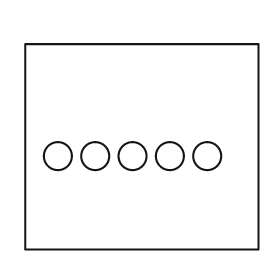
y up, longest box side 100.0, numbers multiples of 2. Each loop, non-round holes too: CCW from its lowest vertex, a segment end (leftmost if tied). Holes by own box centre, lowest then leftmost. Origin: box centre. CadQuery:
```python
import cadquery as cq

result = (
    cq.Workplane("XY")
    .moveTo(-50.0, -44.0)
    .lineTo(50.0, -44.0)
    .lineTo(50.0, 44.0)
    .lineTo(-50.0, 44.0)
    .close()
    .moveTo(-36.0, -4.0)
    .circle(6.0)
    .moveTo(-20.0, -4.0)
    .circle(6.0)
    .moveTo(-4.0, -4.0)
    .circle(6.0)
    .moveTo(12.0, -4.0)
    .circle(6.0)
    .moveTo(28.0, -4.0)
    .circle(6.0)
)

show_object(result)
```